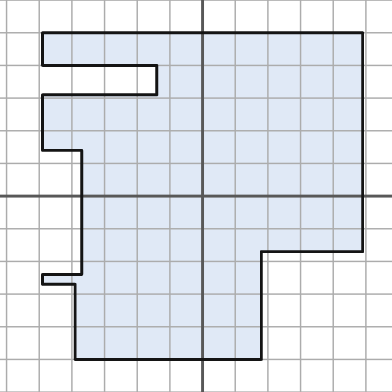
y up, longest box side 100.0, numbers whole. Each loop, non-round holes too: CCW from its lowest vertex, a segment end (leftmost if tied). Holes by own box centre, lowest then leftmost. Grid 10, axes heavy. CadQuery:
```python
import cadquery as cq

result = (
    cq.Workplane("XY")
    .moveTo(-39.0, -50.0)
    .lineTo(18.0, -50.0)
    .lineTo(18.0, -17.0)
    .lineTo(49.0, -17.0)
    .lineTo(49.0, 50.0)
    .lineTo(-49.0, 50.0)
    .lineTo(-49.0, 40.0)
    .lineTo(-14.0, 40.0)
    .lineTo(-14.0, 31.0)
    .lineTo(-49.0, 31.0)
    .lineTo(-49.0, 14.0)
    .lineTo(-37.0, 14.0)
    .lineTo(-37.0, -24.0)
    .lineTo(-49.0, -24.0)
    .lineTo(-49.0, -27.0)
    .lineTo(-39.0, -27.0)
    .close()
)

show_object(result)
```